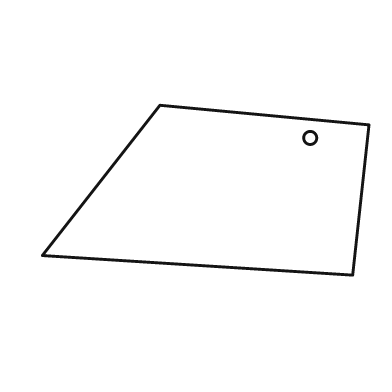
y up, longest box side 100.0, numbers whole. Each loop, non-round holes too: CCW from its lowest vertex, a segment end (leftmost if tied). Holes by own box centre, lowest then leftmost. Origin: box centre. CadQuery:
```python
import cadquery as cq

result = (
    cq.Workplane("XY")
    .moveTo(45.0, -26.0)
    .lineTo(50.0, 20.0)
    .lineTo(-14.0, 26.0)
    .lineTo(-50.0, -20.0)
    .close()
    .moveTo(32.0, 16.0)
    .circle(2.0)
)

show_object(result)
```